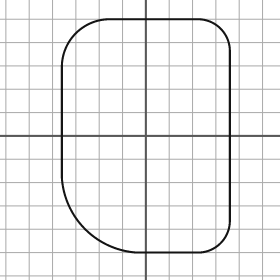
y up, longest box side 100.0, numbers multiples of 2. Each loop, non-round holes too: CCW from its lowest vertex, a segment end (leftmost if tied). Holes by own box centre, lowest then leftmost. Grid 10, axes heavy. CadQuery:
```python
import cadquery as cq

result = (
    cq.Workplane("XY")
    .moveTo(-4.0, -50.0)
    .lineTo(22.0, -50.0)
    .threePointArc((32.0, -46.0), (36.0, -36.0))
    .lineTo(36.0, 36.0)
    .threePointArc((32.0, 46.0), (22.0, 50.0))
    .lineTo(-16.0, 50.0)
    .threePointArc((-30.0, 44.0), (-36.0, 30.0))
    .lineTo(-36.0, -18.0)
    .threePointArc((-26.0, -40.0), (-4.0, -50.0))
    .close()
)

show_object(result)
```